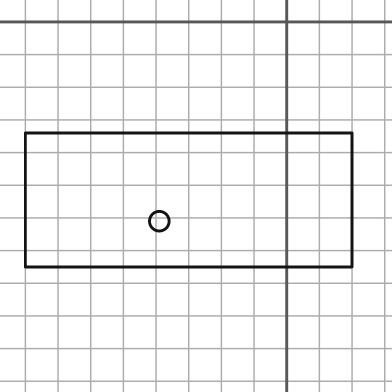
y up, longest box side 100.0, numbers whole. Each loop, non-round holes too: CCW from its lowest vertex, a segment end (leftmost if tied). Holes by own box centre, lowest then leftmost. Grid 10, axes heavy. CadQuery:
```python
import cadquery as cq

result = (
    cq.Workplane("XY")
    .moveTo(-80.0, -75.0)
    .lineTo(20.0, -75.0)
    .lineTo(20.0, -34.0)
    .lineTo(-80.0, -34.0)
    .close()
    .moveTo(-39.0, -61.0)
    .circle(3.0)
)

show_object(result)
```